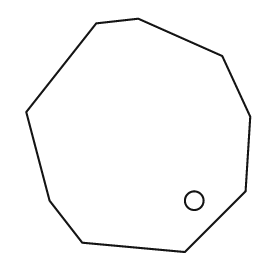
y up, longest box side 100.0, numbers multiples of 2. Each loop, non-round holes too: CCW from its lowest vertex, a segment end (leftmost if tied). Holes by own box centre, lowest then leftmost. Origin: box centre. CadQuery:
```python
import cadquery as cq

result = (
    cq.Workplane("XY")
    .moveTo(20.0, -50.0)
    .lineTo(46.0, -24.0)
    .lineTo(48.0, 8.0)
    .lineTo(36.0, 34.0)
    .lineTo(0.0, 50.0)
    .lineTo(-18.0, 48.0)
    .lineTo(-48.0, 10.0)
    .lineTo(-38.0, -28.0)
    .lineTo(-24.0, -46.0)
    .close()
    .moveTo(24.0, -28.0)
    .circle(4.0)
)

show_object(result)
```